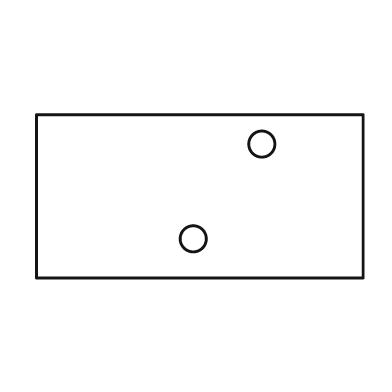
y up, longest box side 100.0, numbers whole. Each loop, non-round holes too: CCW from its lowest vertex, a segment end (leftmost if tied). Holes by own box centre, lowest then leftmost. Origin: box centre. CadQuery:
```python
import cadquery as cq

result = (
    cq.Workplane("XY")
    .moveTo(-50.0, -25.0)
    .lineTo(50.0, -25.0)
    .lineTo(50.0, 25.0)
    .lineTo(-50.0, 25.0)
    .close()
    .moveTo(-2.0, -13.0)
    .circle(4.0)
    .moveTo(19.0, 16.0)
    .circle(4.0)
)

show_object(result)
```